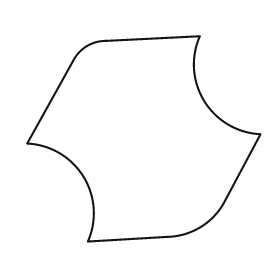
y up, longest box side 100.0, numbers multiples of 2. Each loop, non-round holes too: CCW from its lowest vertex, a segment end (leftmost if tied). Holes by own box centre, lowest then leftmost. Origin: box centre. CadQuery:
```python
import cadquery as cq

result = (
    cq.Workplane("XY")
    .moveTo(-24.0, -44.0)
    .lineTo(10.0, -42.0)
    .threePointArc((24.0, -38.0), (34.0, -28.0))
    .lineTo(50.0, 2.0)
    .threePointArc((26.0, 16.0), (24.0, 44.0))
    .lineTo(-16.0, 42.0)
    .threePointArc((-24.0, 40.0), (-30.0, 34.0))
    .lineTo(-50.0, -2.0)
    .threePointArc((-26.0, -16.0), (-24.0, -44.0))
    .close()
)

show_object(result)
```